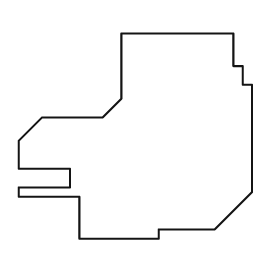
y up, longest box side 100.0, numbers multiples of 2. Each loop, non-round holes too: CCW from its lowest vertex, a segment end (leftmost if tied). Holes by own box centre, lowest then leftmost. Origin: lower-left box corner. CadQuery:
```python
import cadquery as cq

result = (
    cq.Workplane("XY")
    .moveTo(26.0, 0.0)
    .lineTo(60.0, 0.0)
    .lineTo(60.0, 4.0)
    .lineTo(84.0, 4.0)
    .lineTo(100.0, 20.0)
    .lineTo(100.0, 66.0)
    .lineTo(96.0, 66.0)
    .lineTo(96.0, 74.0)
    .lineTo(92.0, 74.0)
    .lineTo(92.0, 88.0)
    .lineTo(44.0, 88.0)
    .lineTo(44.0, 60.0)
    .lineTo(36.0, 52.0)
    .lineTo(10.0, 52.0)
    .lineTo(0.0, 42.0)
    .lineTo(0.0, 30.0)
    .lineTo(22.0, 30.0)
    .lineTo(22.0, 22.0)
    .lineTo(0.0, 22.0)
    .lineTo(0.0, 18.0)
    .lineTo(26.0, 18.0)
    .close()
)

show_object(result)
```